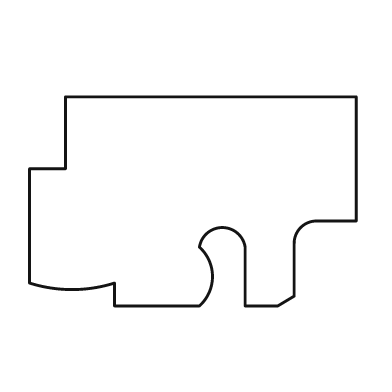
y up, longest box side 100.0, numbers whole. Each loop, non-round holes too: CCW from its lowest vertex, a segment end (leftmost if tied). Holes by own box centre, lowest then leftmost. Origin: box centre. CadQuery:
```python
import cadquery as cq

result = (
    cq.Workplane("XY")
    .moveTo(-24.0, -32.0)
    .lineTo(2.0, -32.0)
    .threePointArc((6.0, -23.0), (2.0, -14.0))
    .threePointArc((9.0, -8.0), (16.0, -14.0))
    .lineTo(16.0, -32.0)
    .lineTo(26.0, -32.0)
    .lineTo(31.0, -29.0)
    .lineTo(31.0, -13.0)
    .threePointArc((33.0, -8.0), (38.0, -6.0))
    .lineTo(50.0, -6.0)
    .lineTo(50.0, 32.0)
    .lineTo(-39.0, 32.0)
    .lineTo(-39.0, 10.0)
    .lineTo(-50.0, 10.0)
    .lineTo(-50.0, -25.0)
    .threePointArc((-37.0, -27.0), (-24.0, -25.0))
    .close()
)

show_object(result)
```